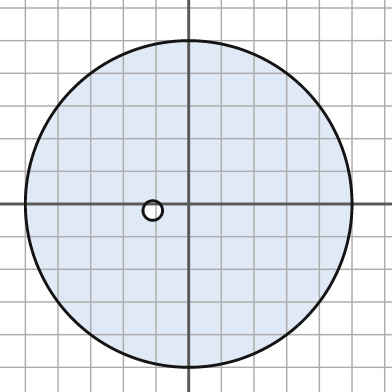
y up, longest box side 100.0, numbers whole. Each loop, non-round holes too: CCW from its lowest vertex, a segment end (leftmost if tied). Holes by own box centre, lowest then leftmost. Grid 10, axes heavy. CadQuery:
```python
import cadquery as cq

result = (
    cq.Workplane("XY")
    .moveTo(0.0, 0.0)
    .circle(50.0)
    .moveTo(-11.0, -2.0)
    .circle(3.0)
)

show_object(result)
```